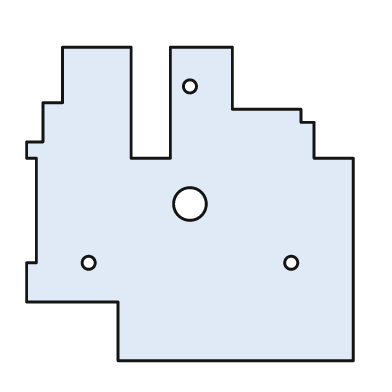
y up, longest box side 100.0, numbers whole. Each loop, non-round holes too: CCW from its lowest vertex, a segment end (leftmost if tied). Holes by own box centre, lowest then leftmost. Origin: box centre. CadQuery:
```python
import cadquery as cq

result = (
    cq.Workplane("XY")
    .moveTo(-22.0, -48.0)
    .lineTo(50.0, -48.0)
    .lineTo(50.0, 14.0)
    .lineTo(38.0, 14.0)
    .lineTo(38.0, 25.0)
    .lineTo(34.0, 25.0)
    .lineTo(34.0, 29.0)
    .lineTo(13.0, 29.0)
    .lineTo(13.0, 48.0)
    .lineTo(-6.0, 48.0)
    .lineTo(-6.0, 14.0)
    .lineTo(-18.0, 14.0)
    .lineTo(-18.0, 48.0)
    .lineTo(-39.0, 48.0)
    .lineTo(-39.0, 31.0)
    .lineTo(-45.0, 31.0)
    .lineTo(-45.0, 19.0)
    .lineTo(-50.0, 19.0)
    .lineTo(-50.0, 14.0)
    .lineTo(-47.0, 14.0)
    .lineTo(-47.0, -18.0)
    .lineTo(-50.0, -18.0)
    .lineTo(-50.0, -30.0)
    .lineTo(-22.0, -30.0)
    .close()
    .moveTo(-31.0, -18.0)
    .circle(2.0)
    .moveTo(31.0, -18.0)
    .circle(2.0)
    .moveTo(0.0, 0.0)
    .circle(5.0)
    .moveTo(0.0, 36.0)
    .circle(2.0)
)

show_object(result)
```